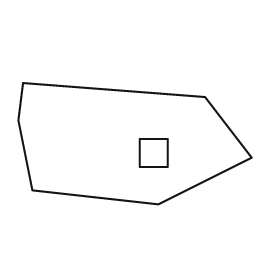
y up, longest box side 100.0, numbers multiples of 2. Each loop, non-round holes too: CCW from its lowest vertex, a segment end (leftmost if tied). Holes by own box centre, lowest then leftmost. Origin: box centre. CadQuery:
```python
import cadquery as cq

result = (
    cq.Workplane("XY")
    .moveTo(10.0, -26.0)
    .lineTo(50.0, -6.0)
    .lineTo(30.0, 20.0)
    .lineTo(-48.0, 26.0)
    .lineTo(-50.0, 10.0)
    .lineTo(-44.0, -20.0)
    .close()
    .moveTo(2.0, -10.0)
    .lineTo(14.0, -10.0)
    .lineTo(14.0, 2.0)
    .lineTo(2.0, 2.0)
    .close()
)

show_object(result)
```